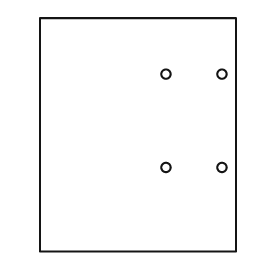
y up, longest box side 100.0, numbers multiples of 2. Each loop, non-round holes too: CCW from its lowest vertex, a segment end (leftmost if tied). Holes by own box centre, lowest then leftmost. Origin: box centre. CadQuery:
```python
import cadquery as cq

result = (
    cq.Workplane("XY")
    .moveTo(-42.0, -50.0)
    .lineTo(42.0, -50.0)
    .lineTo(42.0, 50.0)
    .lineTo(-42.0, 50.0)
    .close()
    .moveTo(12.0, -14.0)
    .circle(2.0)
    .moveTo(36.0, -14.0)
    .circle(2.0)
    .moveTo(12.0, 26.0)
    .circle(2.0)
    .moveTo(36.0, 26.0)
    .circle(2.0)
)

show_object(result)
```